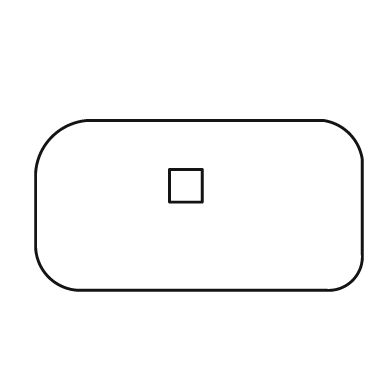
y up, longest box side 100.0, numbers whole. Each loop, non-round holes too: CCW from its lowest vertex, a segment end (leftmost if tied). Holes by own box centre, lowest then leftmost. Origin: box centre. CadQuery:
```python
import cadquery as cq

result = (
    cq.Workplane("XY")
    .moveTo(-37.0, -26.0)
    .lineTo(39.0, -26.0)
    .threePointArc((47.0, -23.0), (50.0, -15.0))
    .lineTo(50.0, 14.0)
    .threePointArc((46.0, 22.0), (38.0, 26.0))
    .lineTo(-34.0, 26.0)
    .threePointArc((-45.0, 21.0), (-50.0, 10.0))
    .lineTo(-50.0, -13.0)
    .threePointArc((-46.0, -22.0), (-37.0, -26.0))
    .close()
    .moveTo(-9.0, 1.0)
    .lineTo(1.0, 1.0)
    .lineTo(1.0, 11.0)
    .lineTo(-9.0, 11.0)
    .close()
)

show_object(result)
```